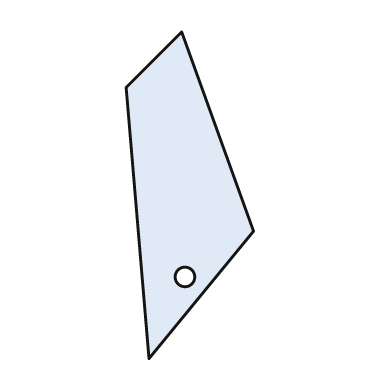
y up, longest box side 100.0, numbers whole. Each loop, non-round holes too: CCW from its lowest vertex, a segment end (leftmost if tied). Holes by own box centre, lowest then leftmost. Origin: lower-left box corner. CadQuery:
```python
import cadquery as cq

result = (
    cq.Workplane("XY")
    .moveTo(7.0, 0.0)
    .lineTo(39.0, 39.0)
    .lineTo(17.0, 100.0)
    .lineTo(0.0, 83.0)
    .close()
    .moveTo(18.0, 25.0)
    .circle(3.0)
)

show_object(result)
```